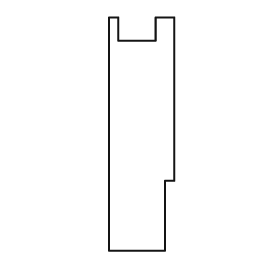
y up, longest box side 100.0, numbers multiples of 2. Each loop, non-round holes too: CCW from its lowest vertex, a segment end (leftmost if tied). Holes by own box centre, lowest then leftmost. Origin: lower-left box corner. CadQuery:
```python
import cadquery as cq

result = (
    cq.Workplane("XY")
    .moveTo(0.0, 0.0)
    .lineTo(24.0, 0.0)
    .lineTo(24.0, 30.0)
    .lineTo(28.0, 30.0)
    .lineTo(28.0, 100.0)
    .lineTo(20.0, 100.0)
    .lineTo(20.0, 90.0)
    .lineTo(4.0, 90.0)
    .lineTo(4.0, 100.0)
    .lineTo(0.0, 100.0)
    .close()
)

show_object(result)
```